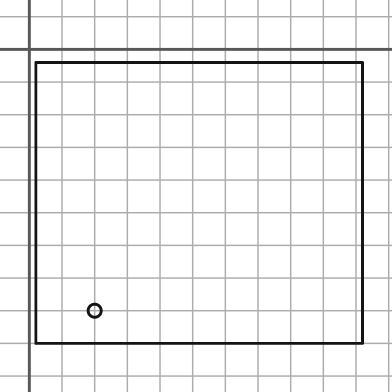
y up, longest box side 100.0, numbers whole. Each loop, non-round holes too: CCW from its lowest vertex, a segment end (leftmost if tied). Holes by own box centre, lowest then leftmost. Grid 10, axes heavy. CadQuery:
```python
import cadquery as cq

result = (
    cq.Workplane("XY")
    .moveTo(2.0, -90.0)
    .lineTo(102.0, -90.0)
    .lineTo(102.0, -4.0)
    .lineTo(2.0, -4.0)
    .close()
    .moveTo(20.0, -80.0)
    .circle(2.0)
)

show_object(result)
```